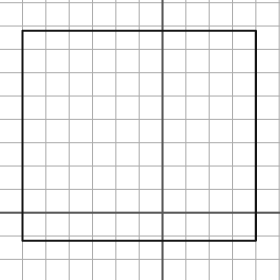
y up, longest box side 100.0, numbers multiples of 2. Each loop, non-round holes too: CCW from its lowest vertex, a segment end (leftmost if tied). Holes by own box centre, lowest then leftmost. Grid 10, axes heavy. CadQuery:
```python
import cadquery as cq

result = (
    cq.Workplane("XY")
    .moveTo(-60.0, -12.0)
    .lineTo(40.0, -12.0)
    .lineTo(40.0, 78.0)
    .lineTo(-60.0, 78.0)
    .close()
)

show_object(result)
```